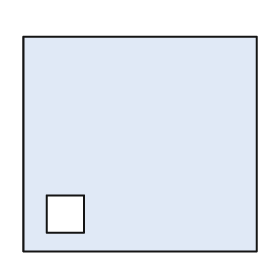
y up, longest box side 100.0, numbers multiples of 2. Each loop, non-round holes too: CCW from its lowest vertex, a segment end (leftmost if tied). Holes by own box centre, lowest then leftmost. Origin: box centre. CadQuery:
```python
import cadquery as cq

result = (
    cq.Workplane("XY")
    .moveTo(-50.0, -46.0)
    .lineTo(50.0, -46.0)
    .lineTo(50.0, 46.0)
    .lineTo(-50.0, 46.0)
    .close()
    .moveTo(-40.0, -38.0)
    .lineTo(-24.0, -38.0)
    .lineTo(-24.0, -22.0)
    .lineTo(-40.0, -22.0)
    .close()
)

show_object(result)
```